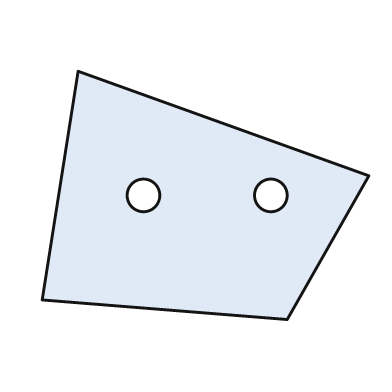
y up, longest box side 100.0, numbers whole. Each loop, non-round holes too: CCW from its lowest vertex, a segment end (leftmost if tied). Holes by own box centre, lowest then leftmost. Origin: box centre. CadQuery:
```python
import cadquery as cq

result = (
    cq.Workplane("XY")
    .moveTo(25.0, -38.0)
    .lineTo(50.0, 6.0)
    .lineTo(-39.0, 38.0)
    .lineTo(-50.0, -32.0)
    .close()
    .moveTo(-19.0, 0.0)
    .circle(5.0)
    .moveTo(20.0, 0.0)
    .circle(5.0)
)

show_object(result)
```